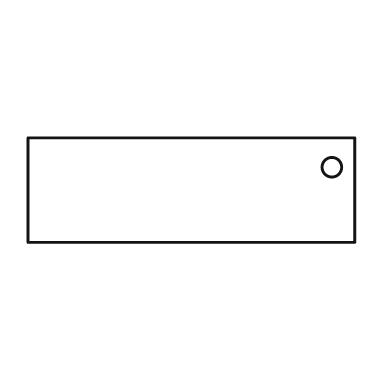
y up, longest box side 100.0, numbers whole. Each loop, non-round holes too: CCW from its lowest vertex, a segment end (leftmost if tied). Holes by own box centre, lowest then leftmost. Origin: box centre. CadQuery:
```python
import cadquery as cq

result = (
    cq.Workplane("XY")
    .moveTo(-50.0, -16.0)
    .lineTo(50.0, -16.0)
    .lineTo(50.0, 16.0)
    .lineTo(-50.0, 16.0)
    .close()
    .moveTo(43.0, 7.0)
    .circle(3.0)
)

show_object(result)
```